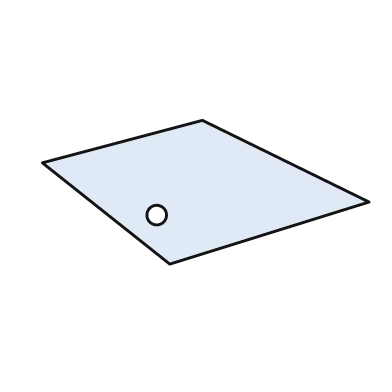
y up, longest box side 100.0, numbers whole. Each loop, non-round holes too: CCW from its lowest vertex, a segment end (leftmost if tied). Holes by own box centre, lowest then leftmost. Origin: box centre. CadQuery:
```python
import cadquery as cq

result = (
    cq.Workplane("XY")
    .moveTo(-11.0, -22.0)
    .lineTo(50.0, -3.0)
    .lineTo(-1.0, 22.0)
    .lineTo(-50.0, 9.0)
    .close()
    .moveTo(-15.0, -7.0)
    .circle(3.0)
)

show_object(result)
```